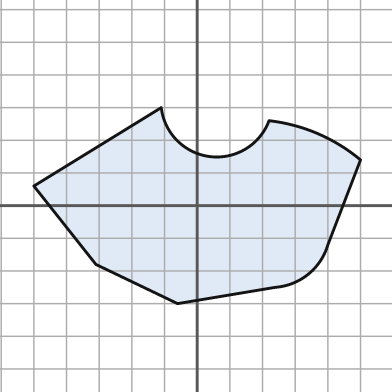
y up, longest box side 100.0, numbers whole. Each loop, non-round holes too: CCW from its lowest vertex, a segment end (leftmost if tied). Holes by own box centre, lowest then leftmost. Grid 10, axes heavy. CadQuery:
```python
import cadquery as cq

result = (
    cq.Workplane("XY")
    .moveTo(-6.0, -30.0)
    .lineTo(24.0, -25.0)
    .threePointArc((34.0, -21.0), (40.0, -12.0))
    .lineTo(50.0, 14.0)
    .threePointArc((37.0, 22.0), (22.0, 26.0))
    .threePointArc((4.0, 15.0), (-11.0, 30.0))
    .lineTo(-50.0, 6.0)
    .lineTo(-31.0, -18.0)
    .close()
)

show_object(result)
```